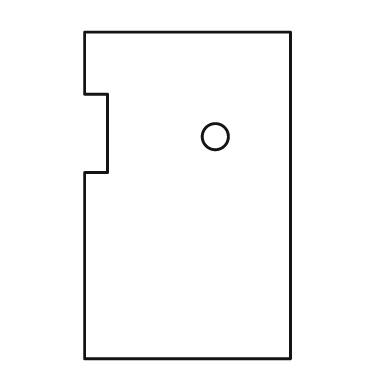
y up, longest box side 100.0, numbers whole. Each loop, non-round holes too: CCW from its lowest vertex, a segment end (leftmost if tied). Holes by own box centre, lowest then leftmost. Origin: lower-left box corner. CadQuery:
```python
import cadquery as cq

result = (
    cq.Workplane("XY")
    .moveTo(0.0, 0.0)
    .lineTo(63.0, 0.0)
    .lineTo(63.0, 100.0)
    .lineTo(0.0, 100.0)
    .lineTo(0.0, 81.0)
    .lineTo(7.0, 81.0)
    .lineTo(7.0, 57.0)
    .lineTo(0.0, 57.0)
    .close()
    .moveTo(40.0, 68.0)
    .circle(4.0)
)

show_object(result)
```